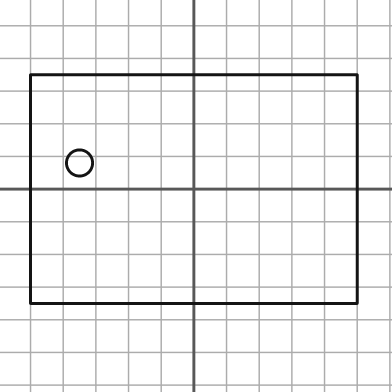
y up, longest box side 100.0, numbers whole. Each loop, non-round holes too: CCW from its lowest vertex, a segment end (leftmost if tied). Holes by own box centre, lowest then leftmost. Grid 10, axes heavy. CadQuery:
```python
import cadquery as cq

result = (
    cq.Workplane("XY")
    .moveTo(-50.0, -35.0)
    .lineTo(50.0, -35.0)
    .lineTo(50.0, 35.0)
    .lineTo(-50.0, 35.0)
    .close()
    .moveTo(-35.0, 8.0)
    .circle(4.0)
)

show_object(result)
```